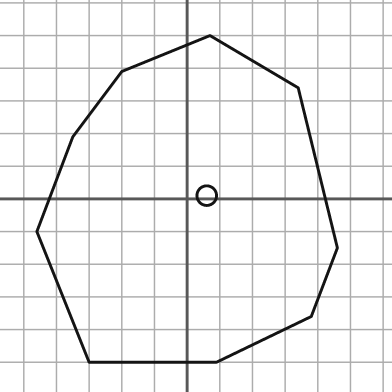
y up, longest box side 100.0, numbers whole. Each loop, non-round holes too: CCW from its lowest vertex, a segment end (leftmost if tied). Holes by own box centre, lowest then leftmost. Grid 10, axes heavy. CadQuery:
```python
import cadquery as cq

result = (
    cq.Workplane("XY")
    .moveTo(-30.0, -50.0)
    .lineTo(9.0, -50.0)
    .lineTo(38.0, -36.0)
    .lineTo(46.0, -15.0)
    .lineTo(34.0, 34.0)
    .lineTo(7.0, 50.0)
    .lineTo(-20.0, 39.0)
    .lineTo(-35.0, 19.0)
    .lineTo(-46.0, -10.0)
    .close()
    .moveTo(6.0, 1.0)
    .circle(3.0)
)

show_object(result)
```